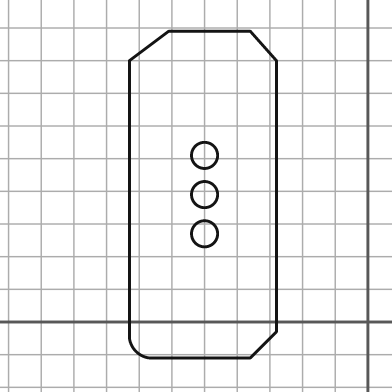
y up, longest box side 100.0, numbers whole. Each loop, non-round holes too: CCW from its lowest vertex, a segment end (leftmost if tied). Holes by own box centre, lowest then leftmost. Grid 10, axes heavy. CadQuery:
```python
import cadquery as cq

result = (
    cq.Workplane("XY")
    .moveTo(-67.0, -11.0)
    .lineTo(-36.0, -11.0)
    .lineTo(-28.0, -3.0)
    .lineTo(-28.0, 80.0)
    .lineTo(-36.0, 89.0)
    .lineTo(-61.0, 89.0)
    .lineTo(-73.0, 80.0)
    .lineTo(-73.0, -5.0)
    .threePointArc((-71.0, -9.0), (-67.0, -11.0))
    .close()
    .moveTo(-50.0, 27.0)
    .circle(4.0)
    .moveTo(-50.0, 39.0)
    .circle(4.0)
    .moveTo(-50.0, 51.0)
    .circle(4.0)
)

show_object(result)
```